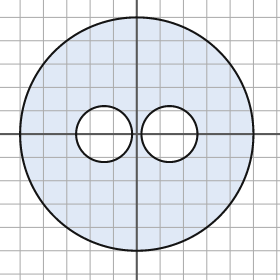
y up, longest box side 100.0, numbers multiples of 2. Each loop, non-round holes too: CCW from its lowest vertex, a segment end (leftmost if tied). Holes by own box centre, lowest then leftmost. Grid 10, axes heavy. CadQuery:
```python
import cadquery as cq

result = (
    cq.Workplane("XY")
    .moveTo(0.0, 0.0)
    .circle(50.0)
    .moveTo(-14.0, 0.0)
    .circle(12.0)
    .moveTo(14.0, 0.0)
    .circle(12.0)
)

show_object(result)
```